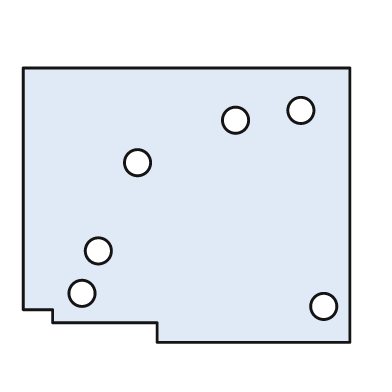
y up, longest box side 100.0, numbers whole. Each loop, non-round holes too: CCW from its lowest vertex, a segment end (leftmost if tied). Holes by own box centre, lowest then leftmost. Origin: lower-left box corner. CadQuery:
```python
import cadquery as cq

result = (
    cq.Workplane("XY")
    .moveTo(41.0, 0.0)
    .lineTo(100.0, 0.0)
    .lineTo(100.0, 84.0)
    .lineTo(0.0, 84.0)
    .lineTo(0.0, 10.0)
    .lineTo(9.0, 10.0)
    .lineTo(9.0, 6.0)
    .lineTo(41.0, 6.0)
    .close()
    .moveTo(92.0, 11.0)
    .circle(4.0)
    .moveTo(18.0, 15.0)
    .circle(4.0)
    .moveTo(23.0, 28.0)
    .circle(4.0)
    .moveTo(35.0, 55.0)
    .circle(4.0)
    .moveTo(65.0, 68.0)
    .circle(4.0)
    .moveTo(85.0, 71.0)
    .circle(4.0)
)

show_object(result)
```